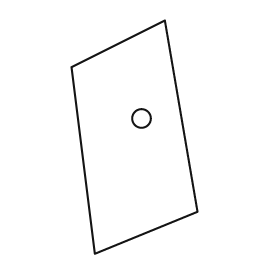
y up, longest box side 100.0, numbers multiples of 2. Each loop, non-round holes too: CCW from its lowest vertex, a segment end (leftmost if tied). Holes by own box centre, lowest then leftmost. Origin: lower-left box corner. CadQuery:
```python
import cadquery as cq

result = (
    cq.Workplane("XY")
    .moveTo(10.0, 0.0)
    .lineTo(54.0, 18.0)
    .lineTo(40.0, 100.0)
    .lineTo(0.0, 80.0)
    .close()
    .moveTo(30.0, 58.0)
    .circle(4.0)
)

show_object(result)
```